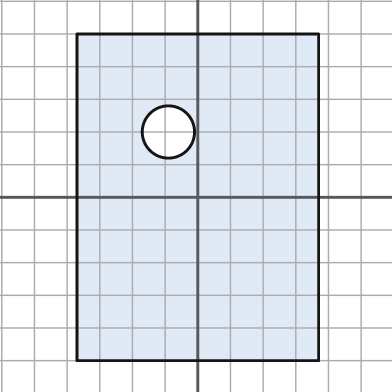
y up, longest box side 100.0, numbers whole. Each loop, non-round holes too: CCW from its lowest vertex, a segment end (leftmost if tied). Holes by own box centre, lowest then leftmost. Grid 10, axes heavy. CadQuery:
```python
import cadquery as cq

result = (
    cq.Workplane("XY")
    .moveTo(-37.0, -50.0)
    .lineTo(37.0, -50.0)
    .lineTo(37.0, 50.0)
    .lineTo(-37.0, 50.0)
    .close()
    .moveTo(-9.0, 20.0)
    .circle(8.0)
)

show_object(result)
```